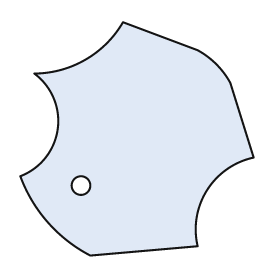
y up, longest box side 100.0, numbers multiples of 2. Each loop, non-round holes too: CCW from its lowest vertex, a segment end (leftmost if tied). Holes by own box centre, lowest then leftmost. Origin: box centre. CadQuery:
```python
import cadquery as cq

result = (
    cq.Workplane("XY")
    .moveTo(-20.0, -50.0)
    .lineTo(26.0, -46.0)
    .threePointArc((30.0, -22.0), (50.0, -8.0))
    .lineTo(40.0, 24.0)
    .threePointArc((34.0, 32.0), (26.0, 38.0))
    .lineTo(-6.0, 50.0)
    .threePointArc((-22.0, 34.0), (-44.0, 28.0))
    .threePointArc((-34.0, 4.0), (-50.0, -16.0))
    .threePointArc((-38.0, -36.0), (-20.0, -50.0))
    .close()
    .moveTo(-24.0, -20.0)
    .circle(4.0)
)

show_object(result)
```